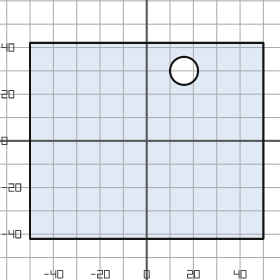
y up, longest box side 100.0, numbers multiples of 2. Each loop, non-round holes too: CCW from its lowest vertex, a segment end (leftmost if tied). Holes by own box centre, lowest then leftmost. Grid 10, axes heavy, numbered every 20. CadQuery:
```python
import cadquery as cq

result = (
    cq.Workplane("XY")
    .moveTo(-50.0, -42.0)
    .lineTo(50.0, -42.0)
    .lineTo(50.0, 42.0)
    .lineTo(-50.0, 42.0)
    .close()
    .moveTo(16.0, 30.0)
    .circle(6.0)
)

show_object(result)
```